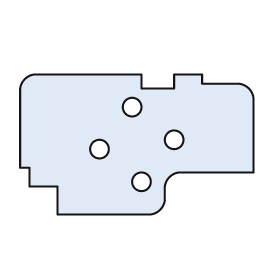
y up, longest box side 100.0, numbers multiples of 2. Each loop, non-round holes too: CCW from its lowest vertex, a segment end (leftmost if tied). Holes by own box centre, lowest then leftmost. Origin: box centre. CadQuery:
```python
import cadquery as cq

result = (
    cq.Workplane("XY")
    .moveTo(-34.0, -30.0)
    .lineTo(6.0, -30.0)
    .threePointArc((10.0, -28.0), (12.0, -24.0))
    .lineTo(12.0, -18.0)
    .threePointArc((14.0, -14.0), (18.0, -12.0))
    .lineTo(50.0, -12.0)
    .lineTo(50.0, 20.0)
    .threePointArc((48.0, 24.0), (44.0, 26.0))
    .lineTo(28.0, 26.0)
    .lineTo(28.0, 30.0)
    .lineTo(16.0, 30.0)
    .lineTo(16.0, 24.0)
    .lineTo(2.0, 24.0)
    .lineTo(2.0, 30.0)
    .lineTo(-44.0, 30.0)
    .threePointArc((-48.0, 28.0), (-50.0, 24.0))
    .lineTo(-50.0, -10.0)
    .lineTo(-46.0, -10.0)
    .lineTo(-46.0, -18.0)
    .lineTo(-34.0, -18.0)
    .close()
    .moveTo(2.0, -16.0)
    .circle(4.0)
    .moveTo(-16.0, -2.0)
    .circle(4.0)
    .moveTo(16.0, 2.0)
    .circle(4.0)
    .moveTo(-2.0, 16.0)
    .circle(4.0)
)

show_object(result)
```